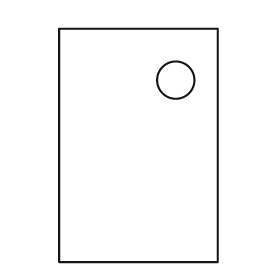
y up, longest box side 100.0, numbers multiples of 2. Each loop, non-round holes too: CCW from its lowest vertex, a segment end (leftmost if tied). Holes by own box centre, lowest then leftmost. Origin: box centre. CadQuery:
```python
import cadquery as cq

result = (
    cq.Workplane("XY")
    .moveTo(-34.0, -50.0)
    .lineTo(34.0, -50.0)
    .lineTo(34.0, 50.0)
    .lineTo(-34.0, 50.0)
    .close()
    .moveTo(16.0, 28.0)
    .circle(8.0)
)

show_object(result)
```